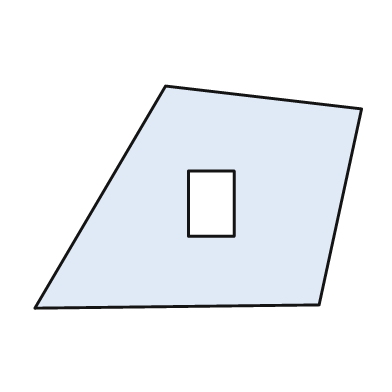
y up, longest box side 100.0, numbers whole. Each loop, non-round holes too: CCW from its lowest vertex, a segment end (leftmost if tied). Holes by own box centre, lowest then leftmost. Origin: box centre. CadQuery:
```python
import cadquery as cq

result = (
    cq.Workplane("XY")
    .moveTo(-50.0, -34.0)
    .lineTo(37.0, -33.0)
    .lineTo(50.0, 27.0)
    .lineTo(-10.0, 34.0)
    .close()
    .moveTo(-3.0, -12.0)
    .lineTo(11.0, -12.0)
    .lineTo(11.0, 8.0)
    .lineTo(-3.0, 8.0)
    .close()
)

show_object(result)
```